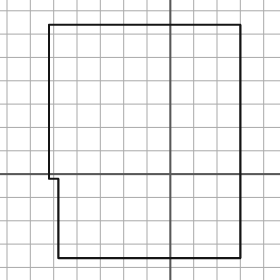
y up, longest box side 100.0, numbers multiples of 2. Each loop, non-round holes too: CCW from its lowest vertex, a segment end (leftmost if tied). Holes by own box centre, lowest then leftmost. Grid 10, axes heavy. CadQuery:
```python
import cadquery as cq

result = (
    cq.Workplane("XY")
    .moveTo(-48.0, -36.0)
    .lineTo(30.0, -36.0)
    .lineTo(30.0, 64.0)
    .lineTo(-52.0, 64.0)
    .lineTo(-52.0, -2.0)
    .lineTo(-48.0, -2.0)
    .close()
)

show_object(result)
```